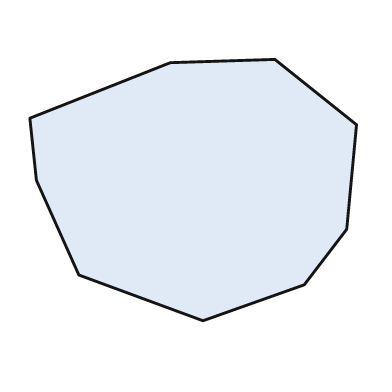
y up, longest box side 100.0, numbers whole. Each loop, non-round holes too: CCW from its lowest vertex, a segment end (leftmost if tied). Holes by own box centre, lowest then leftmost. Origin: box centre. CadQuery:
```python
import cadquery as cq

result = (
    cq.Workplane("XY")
    .moveTo(3.0, -40.0)
    .lineTo(34.0, -29.0)
    .lineTo(47.0, -12.0)
    .lineTo(50.0, 20.0)
    .lineTo(25.0, 40.0)
    .lineTo(-7.0, 39.0)
    .lineTo(-50.0, 22.0)
    .lineTo(-48.0, 3.0)
    .lineTo(-35.0, -26.0)
    .close()
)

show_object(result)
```